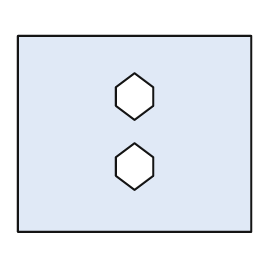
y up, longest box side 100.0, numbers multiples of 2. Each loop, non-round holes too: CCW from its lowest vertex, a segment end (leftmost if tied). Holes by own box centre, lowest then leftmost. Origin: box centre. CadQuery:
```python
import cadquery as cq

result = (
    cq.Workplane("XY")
    .moveTo(-50.0, -42.0)
    .lineTo(50.0, -42.0)
    .lineTo(50.0, 42.0)
    .lineTo(-50.0, 42.0)
    .close()
    .moveTo(0.0, -24.0)
    .lineTo(8.0, -18.0)
    .lineTo(8.0, -10.0)
    .lineTo(0.0, -4.0)
    .lineTo(-8.0, -10.0)
    .lineTo(-8.0, -18.0)
    .close()
    .moveTo(0.0, 6.0)
    .lineTo(8.0, 12.0)
    .lineTo(8.0, 20.0)
    .lineTo(0.0, 26.0)
    .lineTo(-8.0, 20.0)
    .lineTo(-8.0, 12.0)
    .close()
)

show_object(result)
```